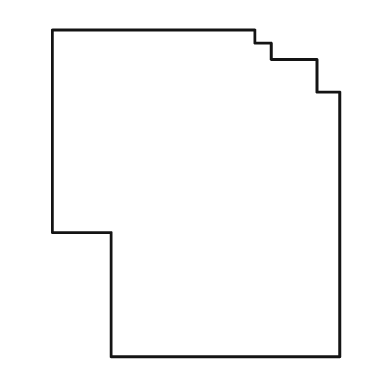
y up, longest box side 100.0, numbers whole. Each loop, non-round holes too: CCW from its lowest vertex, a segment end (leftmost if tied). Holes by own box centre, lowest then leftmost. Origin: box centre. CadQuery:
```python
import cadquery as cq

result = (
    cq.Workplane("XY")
    .moveTo(-26.0, -50.0)
    .lineTo(44.0, -50.0)
    .lineTo(44.0, 31.0)
    .lineTo(37.0, 31.0)
    .lineTo(37.0, 41.0)
    .lineTo(23.0, 41.0)
    .lineTo(23.0, 46.0)
    .lineTo(18.0, 46.0)
    .lineTo(18.0, 50.0)
    .lineTo(-44.0, 50.0)
    .lineTo(-44.0, -12.0)
    .lineTo(-26.0, -12.0)
    .close()
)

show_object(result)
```